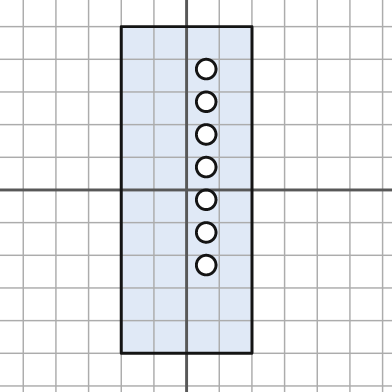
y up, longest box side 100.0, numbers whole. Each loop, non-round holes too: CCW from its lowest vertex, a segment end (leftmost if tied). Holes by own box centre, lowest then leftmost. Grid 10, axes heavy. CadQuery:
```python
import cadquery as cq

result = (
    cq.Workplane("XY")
    .moveTo(-20.0, -50.0)
    .lineTo(20.0, -50.0)
    .lineTo(20.0, 50.0)
    .lineTo(-20.0, 50.0)
    .close()
    .moveTo(6.0, -23.0)
    .circle(3.0)
    .moveTo(6.0, -13.0)
    .circle(3.0)
    .moveTo(6.0, -3.0)
    .circle(3.0)
    .moveTo(6.0, 7.0)
    .circle(3.0)
    .moveTo(6.0, 17.0)
    .circle(3.0)
    .moveTo(6.0, 27.0)
    .circle(3.0)
    .moveTo(6.0, 37.0)
    .circle(3.0)
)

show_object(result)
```